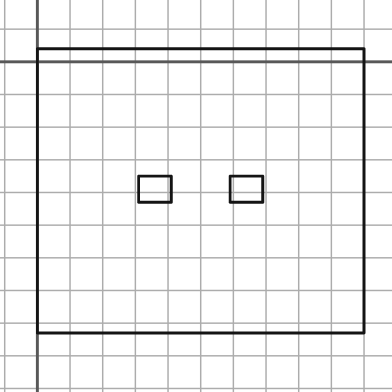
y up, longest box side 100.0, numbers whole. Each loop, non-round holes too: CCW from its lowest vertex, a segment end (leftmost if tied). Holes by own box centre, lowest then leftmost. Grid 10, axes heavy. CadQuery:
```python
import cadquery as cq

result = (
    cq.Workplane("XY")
    .moveTo(0.0, -83.0)
    .lineTo(100.0, -83.0)
    .lineTo(100.0, 4.0)
    .lineTo(0.0, 4.0)
    .close()
    .moveTo(31.0, -43.0)
    .lineTo(41.0, -43.0)
    .lineTo(41.0, -35.0)
    .lineTo(31.0, -35.0)
    .close()
    .moveTo(59.0, -43.0)
    .lineTo(69.0, -43.0)
    .lineTo(69.0, -35.0)
    .lineTo(59.0, -35.0)
    .close()
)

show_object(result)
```